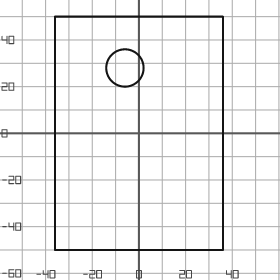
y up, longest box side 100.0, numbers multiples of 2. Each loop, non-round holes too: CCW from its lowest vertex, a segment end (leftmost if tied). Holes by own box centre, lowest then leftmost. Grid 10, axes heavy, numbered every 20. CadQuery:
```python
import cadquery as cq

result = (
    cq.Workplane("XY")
    .moveTo(-36.0, -50.0)
    .lineTo(36.0, -50.0)
    .lineTo(36.0, 50.0)
    .lineTo(-36.0, 50.0)
    .close()
    .moveTo(-6.0, 28.0)
    .circle(8.0)
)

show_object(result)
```